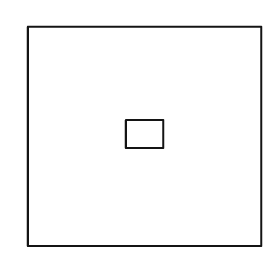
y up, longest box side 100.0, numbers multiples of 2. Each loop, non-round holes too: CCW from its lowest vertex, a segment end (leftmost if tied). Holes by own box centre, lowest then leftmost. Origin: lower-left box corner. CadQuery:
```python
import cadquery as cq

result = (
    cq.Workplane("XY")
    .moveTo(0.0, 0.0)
    .lineTo(100.0, 0.0)
    .lineTo(100.0, 94.0)
    .lineTo(0.0, 94.0)
    .close()
    .moveTo(42.0, 42.0)
    .lineTo(58.0, 42.0)
    .lineTo(58.0, 54.0)
    .lineTo(42.0, 54.0)
    .close()
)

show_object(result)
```